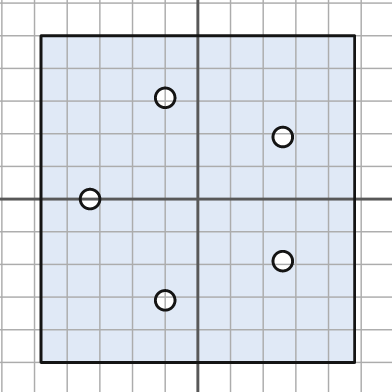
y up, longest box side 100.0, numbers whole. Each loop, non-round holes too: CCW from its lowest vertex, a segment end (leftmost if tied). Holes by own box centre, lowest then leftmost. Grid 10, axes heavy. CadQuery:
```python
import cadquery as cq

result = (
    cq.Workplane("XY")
    .moveTo(-48.0, -50.0)
    .lineTo(48.0, -50.0)
    .lineTo(48.0, 50.0)
    .lineTo(-48.0, 50.0)
    .close()
    .moveTo(-10.0, -31.0)
    .circle(3.0)
    .moveTo(26.0, -19.0)
    .circle(3.0)
    .moveTo(-33.0, 0.0)
    .circle(3.0)
    .moveTo(26.0, 19.0)
    .circle(3.0)
    .moveTo(-10.0, 31.0)
    .circle(3.0)
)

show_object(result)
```